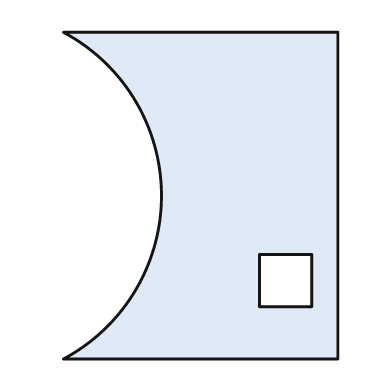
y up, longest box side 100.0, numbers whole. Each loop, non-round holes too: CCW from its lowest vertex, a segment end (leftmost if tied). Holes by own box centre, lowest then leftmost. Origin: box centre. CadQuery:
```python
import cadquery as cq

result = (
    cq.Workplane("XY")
    .moveTo(-42.0, -50.0)
    .lineTo(42.0, -50.0)
    .lineTo(42.0, 50.0)
    .lineTo(-42.0, 50.0)
    .threePointArc((-12.0, 0.0), (-42.0, -50.0))
    .close()
    .moveTo(18.0, -34.0)
    .lineTo(34.0, -34.0)
    .lineTo(34.0, -18.0)
    .lineTo(18.0, -18.0)
    .close()
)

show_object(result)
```